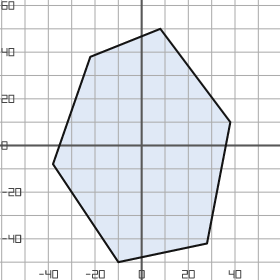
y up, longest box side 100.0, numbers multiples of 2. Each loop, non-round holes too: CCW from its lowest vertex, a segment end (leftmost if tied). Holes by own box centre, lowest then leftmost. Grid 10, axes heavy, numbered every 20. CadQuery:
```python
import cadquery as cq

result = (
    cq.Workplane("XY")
    .moveTo(-10.0, -50.0)
    .lineTo(28.0, -42.0)
    .lineTo(38.0, 10.0)
    .lineTo(8.0, 50.0)
    .lineTo(-22.0, 38.0)
    .lineTo(-38.0, -8.0)
    .close()
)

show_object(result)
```